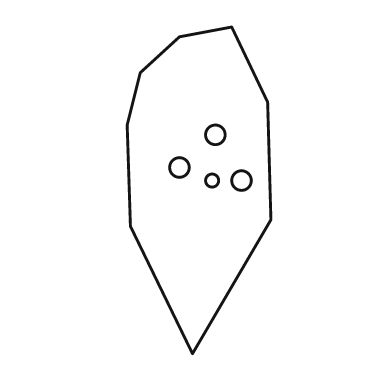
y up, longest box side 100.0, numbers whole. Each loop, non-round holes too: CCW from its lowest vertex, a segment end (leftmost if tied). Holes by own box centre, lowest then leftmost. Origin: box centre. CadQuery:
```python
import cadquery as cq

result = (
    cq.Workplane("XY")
    .moveTo(-2.0, -50.0)
    .lineTo(22.0, -9.0)
    .lineTo(21.0, 27.0)
    .lineTo(10.0, 50.0)
    .lineTo(-6.0, 47.0)
    .lineTo(-18.0, 36.0)
    .lineTo(-22.0, 20.0)
    .lineTo(-21.0, -11.0)
    .close()
    .moveTo(4.0, 3.0)
    .circle(2.0)
    .moveTo(13.0, 3.0)
    .circle(3.0)
    .moveTo(-6.0, 7.0)
    .circle(3.0)
    .moveTo(5.0, 17.0)
    .circle(3.0)
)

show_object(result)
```